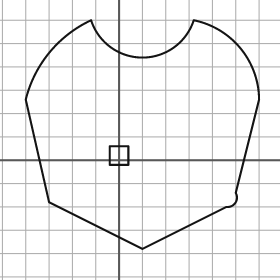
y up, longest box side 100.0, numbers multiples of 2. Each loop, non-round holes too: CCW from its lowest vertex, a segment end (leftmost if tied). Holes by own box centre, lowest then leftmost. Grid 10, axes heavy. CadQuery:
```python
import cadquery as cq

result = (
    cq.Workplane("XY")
    .moveTo(10.0, -38.0)
    .lineTo(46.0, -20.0)
    .threePointArc((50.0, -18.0), (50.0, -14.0))
    .lineTo(60.0, 26.0)
    .threePointArc((52.0, 48.0), (32.0, 60.0))
    .threePointArc((10.0, 44.0), (-12.0, 60.0))
    .threePointArc((-30.0, 46.0), (-40.0, 26.0))
    .lineTo(-30.0, -18.0)
    .close()
    .moveTo(-4.0, -2.0)
    .lineTo(4.0, -2.0)
    .lineTo(4.0, 6.0)
    .lineTo(-4.0, 6.0)
    .close()
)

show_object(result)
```